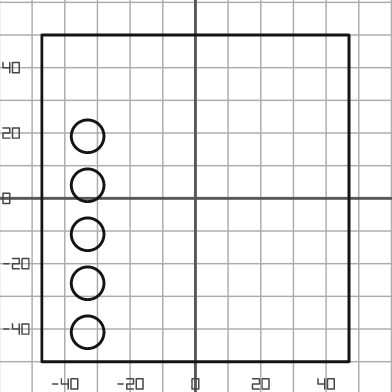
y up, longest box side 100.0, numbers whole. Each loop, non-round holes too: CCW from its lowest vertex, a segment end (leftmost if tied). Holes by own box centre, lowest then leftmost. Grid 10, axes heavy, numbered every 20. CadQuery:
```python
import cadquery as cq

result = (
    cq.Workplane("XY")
    .moveTo(-47.0, -50.0)
    .lineTo(47.0, -50.0)
    .lineTo(47.0, 50.0)
    .lineTo(-47.0, 50.0)
    .close()
    .moveTo(-33.0, -41.0)
    .circle(5.0)
    .moveTo(-33.0, -26.0)
    .circle(5.0)
    .moveTo(-33.0, -11.0)
    .circle(5.0)
    .moveTo(-33.0, 4.0)
    .circle(5.0)
    .moveTo(-33.0, 19.0)
    .circle(5.0)
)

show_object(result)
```